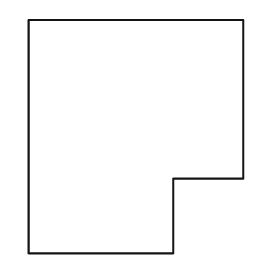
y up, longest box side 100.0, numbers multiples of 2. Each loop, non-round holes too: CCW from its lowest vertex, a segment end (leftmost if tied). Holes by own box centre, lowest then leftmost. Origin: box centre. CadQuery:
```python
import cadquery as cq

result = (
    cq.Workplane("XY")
    .moveTo(-46.0, -50.0)
    .lineTo(16.0, -50.0)
    .lineTo(16.0, -18.0)
    .lineTo(46.0, -18.0)
    .lineTo(46.0, 50.0)
    .lineTo(-46.0, 50.0)
    .close()
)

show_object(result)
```